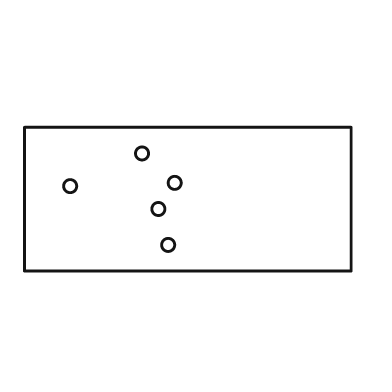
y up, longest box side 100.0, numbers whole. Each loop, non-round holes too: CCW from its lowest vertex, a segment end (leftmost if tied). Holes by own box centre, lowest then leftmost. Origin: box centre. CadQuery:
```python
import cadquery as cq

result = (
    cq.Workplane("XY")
    .moveTo(-50.0, -22.0)
    .lineTo(50.0, -22.0)
    .lineTo(50.0, 22.0)
    .lineTo(-50.0, 22.0)
    .close()
    .moveTo(-6.0, -14.0)
    .circle(2.0)
    .moveTo(-9.0, -3.0)
    .circle(2.0)
    .moveTo(-36.0, 4.0)
    .circle(2.0)
    .moveTo(-4.0, 5.0)
    .circle(2.0)
    .moveTo(-14.0, 14.0)
    .circle(2.0)
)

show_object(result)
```